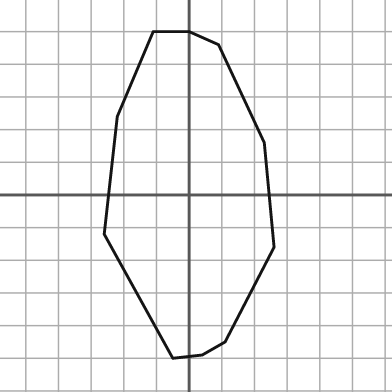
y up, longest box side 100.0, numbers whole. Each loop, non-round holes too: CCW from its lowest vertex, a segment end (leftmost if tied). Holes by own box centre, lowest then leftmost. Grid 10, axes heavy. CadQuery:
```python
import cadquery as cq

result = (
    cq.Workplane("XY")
    .moveTo(-5.0, -50.0)
    .lineTo(4.0, -49.0)
    .lineTo(11.0, -45.0)
    .lineTo(26.0, -16.0)
    .lineTo(23.0, 16.0)
    .lineTo(9.0, 46.0)
    .lineTo(0.0, 50.0)
    .lineTo(-11.0, 50.0)
    .lineTo(-22.0, 24.0)
    .lineTo(-26.0, -12.0)
    .close()
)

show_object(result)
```